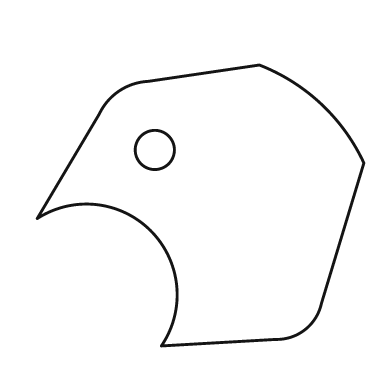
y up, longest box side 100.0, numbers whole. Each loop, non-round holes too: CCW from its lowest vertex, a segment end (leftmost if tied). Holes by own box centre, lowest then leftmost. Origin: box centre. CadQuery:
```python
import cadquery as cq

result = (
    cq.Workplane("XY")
    .moveTo(-12.0, -43.0)
    .lineTo(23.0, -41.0)
    .threePointArc((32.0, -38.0), (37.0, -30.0))
    .lineTo(50.0, 13.0)
    .threePointArc((37.0, 31.0), (18.0, 43.0))
    .lineTo(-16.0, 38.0)
    .threePointArc((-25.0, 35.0), (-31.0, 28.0))
    .lineTo(-50.0, -4.0)
    .threePointArc((-15.0, -8.0), (-12.0, -43.0))
    .close()
    .moveTo(-14.0, 17.0)
    .circle(6.0)
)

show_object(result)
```